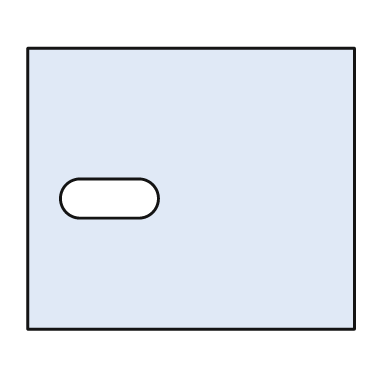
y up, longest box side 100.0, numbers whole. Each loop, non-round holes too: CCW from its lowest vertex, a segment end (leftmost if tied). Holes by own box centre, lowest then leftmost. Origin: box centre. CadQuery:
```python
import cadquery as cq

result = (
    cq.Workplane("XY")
    .moveTo(-50.0, -43.0)
    .lineTo(50.0, -43.0)
    .lineTo(50.0, 43.0)
    .lineTo(-50.0, 43.0)
    .close()
    .moveTo(-34.0, -9.0)
    .lineTo(-16.0, -9.0)
    .threePointArc((-10.0, -3.0), (-16.0, 3.0))
    .lineTo(-34.0, 3.0)
    .threePointArc((-40.0, -3.0), (-34.0, -9.0))
    .close()
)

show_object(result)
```